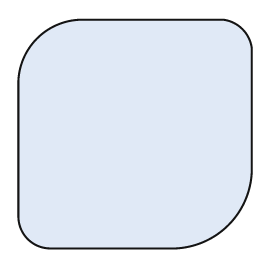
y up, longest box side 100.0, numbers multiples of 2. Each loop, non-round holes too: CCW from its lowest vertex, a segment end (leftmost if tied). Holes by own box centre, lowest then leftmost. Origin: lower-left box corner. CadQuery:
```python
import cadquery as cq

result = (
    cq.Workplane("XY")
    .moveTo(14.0, 0.0)
    .lineTo(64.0, 0.0)
    .threePointArc((90.0, 10.0), (100.0, 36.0))
    .lineTo(100.0, 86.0)
    .threePointArc((96.0, 94.0), (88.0, 98.0))
    .lineTo(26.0, 98.0)
    .threePointArc((8.0, 90.0), (0.0, 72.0))
    .lineTo(0.0, 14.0)
    .threePointArc((4.0, 4.0), (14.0, 0.0))
    .close()
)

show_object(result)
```